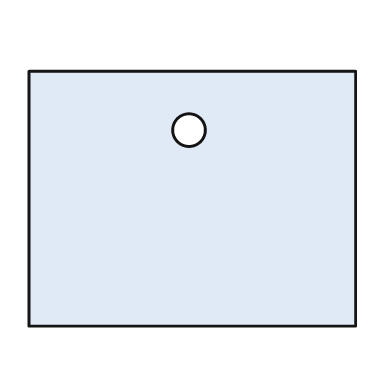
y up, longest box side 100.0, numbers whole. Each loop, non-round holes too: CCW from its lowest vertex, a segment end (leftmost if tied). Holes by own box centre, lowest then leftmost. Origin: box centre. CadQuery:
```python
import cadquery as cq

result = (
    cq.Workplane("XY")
    .moveTo(-50.0, -39.0)
    .lineTo(50.0, -39.0)
    .lineTo(50.0, 39.0)
    .lineTo(-50.0, 39.0)
    .close()
    .moveTo(-1.0, 21.0)
    .circle(5.0)
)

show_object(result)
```